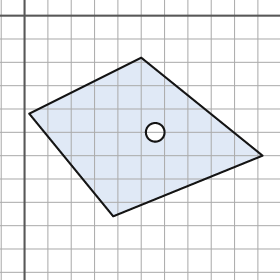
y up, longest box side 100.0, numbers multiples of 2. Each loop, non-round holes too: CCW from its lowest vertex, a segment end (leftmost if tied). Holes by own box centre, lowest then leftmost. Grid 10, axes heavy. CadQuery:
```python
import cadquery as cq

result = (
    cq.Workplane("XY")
    .moveTo(38.0, -86.0)
    .lineTo(102.0, -60.0)
    .lineTo(50.0, -18.0)
    .lineTo(2.0, -42.0)
    .close()
    .moveTo(56.0, -50.0)
    .circle(4.0)
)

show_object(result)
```